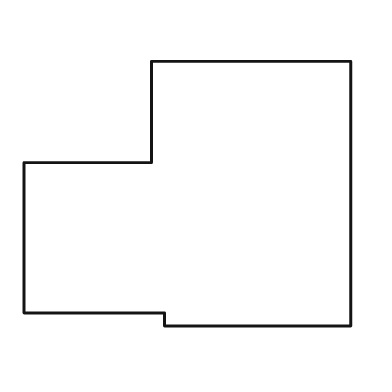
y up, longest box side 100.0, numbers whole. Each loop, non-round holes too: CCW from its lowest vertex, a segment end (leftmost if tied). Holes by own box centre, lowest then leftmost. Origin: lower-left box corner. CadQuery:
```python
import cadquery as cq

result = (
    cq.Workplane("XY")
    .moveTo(43.0, 0.0)
    .lineTo(100.0, 0.0)
    .lineTo(100.0, 81.0)
    .lineTo(39.0, 81.0)
    .lineTo(39.0, 50.0)
    .lineTo(0.0, 50.0)
    .lineTo(0.0, 4.0)
    .lineTo(43.0, 4.0)
    .close()
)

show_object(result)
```